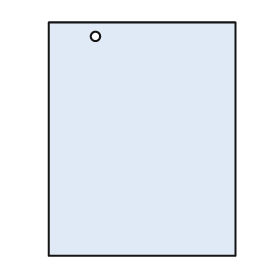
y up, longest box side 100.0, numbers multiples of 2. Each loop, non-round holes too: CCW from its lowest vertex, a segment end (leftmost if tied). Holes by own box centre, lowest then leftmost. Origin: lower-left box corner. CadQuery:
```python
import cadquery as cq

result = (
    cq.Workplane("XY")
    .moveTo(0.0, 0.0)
    .lineTo(80.0, 0.0)
    .lineTo(80.0, 100.0)
    .lineTo(0.0, 100.0)
    .close()
    .moveTo(20.0, 94.0)
    .circle(2.0)
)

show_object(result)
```